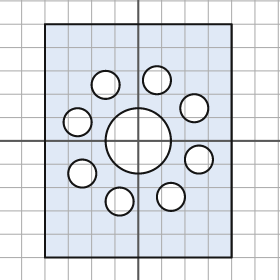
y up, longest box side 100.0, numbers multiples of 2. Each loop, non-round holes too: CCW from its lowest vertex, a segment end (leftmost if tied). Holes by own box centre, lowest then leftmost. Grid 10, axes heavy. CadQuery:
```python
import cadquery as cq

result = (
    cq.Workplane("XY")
    .moveTo(-40.0, -50.0)
    .lineTo(40.0, -50.0)
    .lineTo(40.0, 50.0)
    .lineTo(-40.0, 50.0)
    .close()
    .moveTo(-8.0, -26.0)
    .circle(6.0)
    .moveTo(14.0, -24.0)
    .circle(6.0)
    .moveTo(-24.0, -14.0)
    .circle(6.0)
    .moveTo(26.0, -8.0)
    .circle(6.0)
    .moveTo(0.0, 0.0)
    .circle(14.0)
    .moveTo(-26.0, 8.0)
    .circle(6.0)
    .moveTo(24.0, 14.0)
    .circle(6.0)
    .moveTo(-14.0, 24.0)
    .circle(6.0)
    .moveTo(8.0, 26.0)
    .circle(6.0)
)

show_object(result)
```